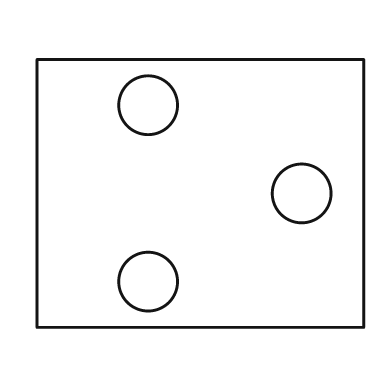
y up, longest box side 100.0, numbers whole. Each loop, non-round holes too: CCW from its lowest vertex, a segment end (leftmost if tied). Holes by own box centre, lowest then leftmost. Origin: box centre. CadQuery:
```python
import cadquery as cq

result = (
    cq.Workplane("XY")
    .moveTo(-50.0, -41.0)
    .lineTo(50.0, -41.0)
    .lineTo(50.0, 41.0)
    .lineTo(-50.0, 41.0)
    .close()
    .moveTo(-16.0, -27.0)
    .circle(9.0)
    .moveTo(31.0, 0.0)
    .circle(9.0)
    .moveTo(-16.0, 27.0)
    .circle(9.0)
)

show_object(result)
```